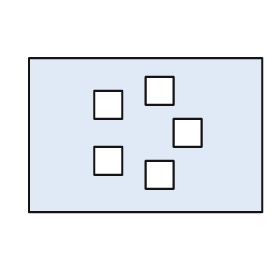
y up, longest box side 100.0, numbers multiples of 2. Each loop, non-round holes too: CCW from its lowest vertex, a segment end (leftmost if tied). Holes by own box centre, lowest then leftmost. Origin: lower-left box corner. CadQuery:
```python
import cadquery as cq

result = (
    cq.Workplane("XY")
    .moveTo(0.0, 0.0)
    .lineTo(100.0, 0.0)
    .lineTo(100.0, 66.0)
    .lineTo(0.0, 66.0)
    .close()
    .moveTo(50.0, 10.0)
    .lineTo(62.0, 10.0)
    .lineTo(62.0, 22.0)
    .lineTo(50.0, 22.0)
    .close()
    .moveTo(28.0, 16.0)
    .lineTo(40.0, 16.0)
    .lineTo(40.0, 28.0)
    .lineTo(28.0, 28.0)
    .close()
    .moveTo(62.0, 28.0)
    .lineTo(74.0, 28.0)
    .lineTo(74.0, 40.0)
    .lineTo(62.0, 40.0)
    .close()
    .moveTo(28.0, 40.0)
    .lineTo(40.0, 40.0)
    .lineTo(40.0, 52.0)
    .lineTo(28.0, 52.0)
    .close()
    .moveTo(50.0, 46.0)
    .lineTo(62.0, 46.0)
    .lineTo(62.0, 58.0)
    .lineTo(50.0, 58.0)
    .close()
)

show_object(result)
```